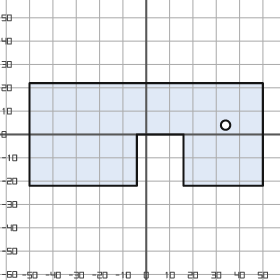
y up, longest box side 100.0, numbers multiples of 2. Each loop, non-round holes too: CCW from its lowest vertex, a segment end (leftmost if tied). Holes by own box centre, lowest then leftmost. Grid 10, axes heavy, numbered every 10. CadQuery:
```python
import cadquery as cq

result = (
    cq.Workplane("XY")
    .moveTo(-50.0, -22.0)
    .lineTo(-4.0, -22.0)
    .lineTo(-4.0, 0.0)
    .lineTo(16.0, 0.0)
    .lineTo(16.0, -22.0)
    .lineTo(50.0, -22.0)
    .lineTo(50.0, 22.0)
    .lineTo(-50.0, 22.0)
    .close()
    .moveTo(34.0, 4.0)
    .circle(2.0)
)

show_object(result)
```